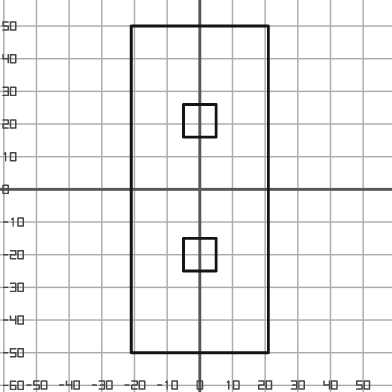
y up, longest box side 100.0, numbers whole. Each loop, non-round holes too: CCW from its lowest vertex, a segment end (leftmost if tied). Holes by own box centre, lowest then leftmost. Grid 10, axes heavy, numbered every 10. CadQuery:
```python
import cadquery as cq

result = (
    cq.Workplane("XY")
    .moveTo(-21.0, -50.0)
    .lineTo(21.0, -50.0)
    .lineTo(21.0, 50.0)
    .lineTo(-21.0, 50.0)
    .close()
    .moveTo(-5.0, -25.0)
    .lineTo(5.0, -25.0)
    .lineTo(5.0, -15.0)
    .lineTo(-5.0, -15.0)
    .close()
    .moveTo(-5.0, 16.0)
    .lineTo(5.0, 16.0)
    .lineTo(5.0, 26.0)
    .lineTo(-5.0, 26.0)
    .close()
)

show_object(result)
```